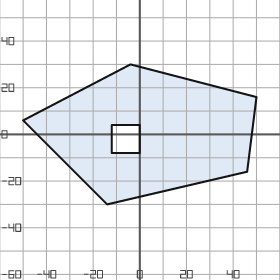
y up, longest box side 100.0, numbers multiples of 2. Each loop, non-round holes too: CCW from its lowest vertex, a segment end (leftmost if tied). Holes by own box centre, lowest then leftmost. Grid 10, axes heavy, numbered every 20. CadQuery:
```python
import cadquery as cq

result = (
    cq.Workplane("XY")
    .moveTo(-14.0, -30.0)
    .lineTo(46.0, -16.0)
    .lineTo(50.0, 16.0)
    .lineTo(-4.0, 30.0)
    .lineTo(-50.0, 6.0)
    .close()
    .moveTo(-12.0, -8.0)
    .lineTo(0.0, -8.0)
    .lineTo(0.0, 4.0)
    .lineTo(-12.0, 4.0)
    .close()
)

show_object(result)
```